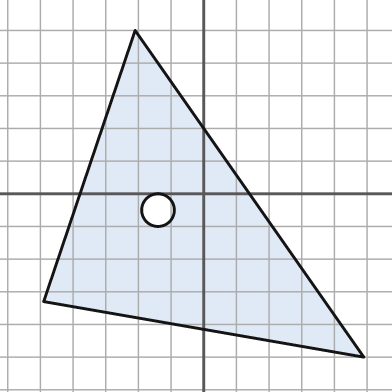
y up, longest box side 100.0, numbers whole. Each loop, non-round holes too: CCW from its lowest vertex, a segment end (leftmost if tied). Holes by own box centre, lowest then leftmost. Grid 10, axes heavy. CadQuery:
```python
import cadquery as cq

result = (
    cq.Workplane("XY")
    .moveTo(49.0, -50.0)
    .lineTo(-21.0, 50.0)
    .lineTo(-49.0, -33.0)
    .close()
    .moveTo(-14.0, -5.0)
    .circle(5.0)
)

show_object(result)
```